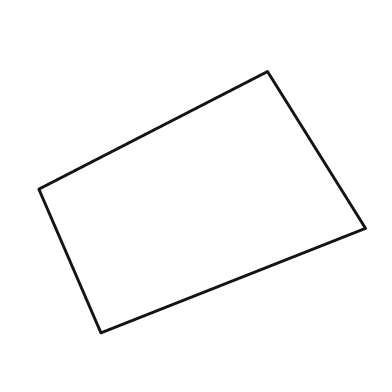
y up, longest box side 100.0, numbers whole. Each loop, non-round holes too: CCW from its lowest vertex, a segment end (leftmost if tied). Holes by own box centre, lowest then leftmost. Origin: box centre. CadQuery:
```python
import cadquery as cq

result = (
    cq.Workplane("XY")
    .moveTo(-31.0, -40.0)
    .lineTo(50.0, -8.0)
    .lineTo(20.0, 40.0)
    .lineTo(-50.0, 4.0)
    .close()
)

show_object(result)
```